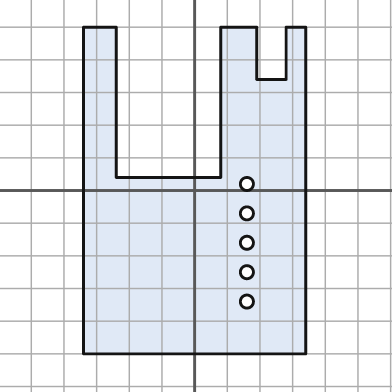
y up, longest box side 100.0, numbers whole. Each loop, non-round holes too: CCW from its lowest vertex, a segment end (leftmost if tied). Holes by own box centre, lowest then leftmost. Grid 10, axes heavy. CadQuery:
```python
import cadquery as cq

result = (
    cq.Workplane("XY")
    .moveTo(-34.0, -50.0)
    .lineTo(34.0, -50.0)
    .lineTo(34.0, 50.0)
    .lineTo(28.0, 50.0)
    .lineTo(28.0, 34.0)
    .lineTo(19.0, 34.0)
    .lineTo(19.0, 50.0)
    .lineTo(8.0, 50.0)
    .lineTo(8.0, 4.0)
    .lineTo(-24.0, 4.0)
    .lineTo(-24.0, 50.0)
    .lineTo(-34.0, 50.0)
    .close()
    .moveTo(16.0, -34.0)
    .circle(2.0)
    .moveTo(16.0, -25.0)
    .circle(2.0)
    .moveTo(16.0, -16.0)
    .circle(2.0)
    .moveTo(16.0, -7.0)
    .circle(2.0)
    .moveTo(16.0, 2.0)
    .circle(2.0)
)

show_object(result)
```